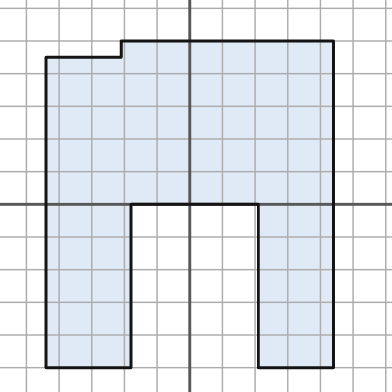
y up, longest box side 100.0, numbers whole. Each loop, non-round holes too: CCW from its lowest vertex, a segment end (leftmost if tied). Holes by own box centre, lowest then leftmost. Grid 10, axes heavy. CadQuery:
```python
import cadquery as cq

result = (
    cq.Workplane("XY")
    .moveTo(-44.0, -50.0)
    .lineTo(-18.0, -50.0)
    .lineTo(-18.0, 0.0)
    .lineTo(21.0, 0.0)
    .lineTo(21.0, -50.0)
    .lineTo(44.0, -50.0)
    .lineTo(44.0, 50.0)
    .lineTo(-21.0, 50.0)
    .lineTo(-21.0, 45.0)
    .lineTo(-44.0, 45.0)
    .close()
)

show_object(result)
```